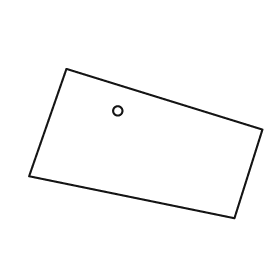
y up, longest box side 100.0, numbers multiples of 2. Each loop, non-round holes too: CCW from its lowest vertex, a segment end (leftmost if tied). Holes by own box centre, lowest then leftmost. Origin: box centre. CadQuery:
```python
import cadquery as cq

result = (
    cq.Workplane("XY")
    .moveTo(38.0, -32.0)
    .lineTo(50.0, 6.0)
    .lineTo(-34.0, 32.0)
    .lineTo(-50.0, -14.0)
    .close()
    .moveTo(-12.0, 14.0)
    .circle(2.0)
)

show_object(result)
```